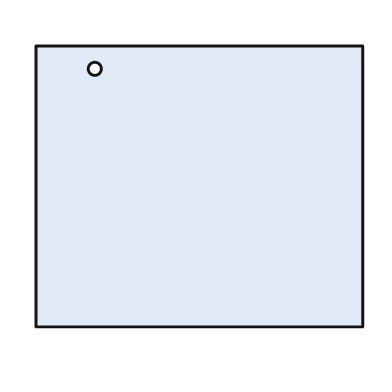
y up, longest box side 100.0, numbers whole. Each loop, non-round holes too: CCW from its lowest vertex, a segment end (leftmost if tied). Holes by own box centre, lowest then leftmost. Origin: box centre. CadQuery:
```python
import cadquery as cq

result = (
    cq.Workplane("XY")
    .moveTo(-50.0, -43.0)
    .lineTo(50.0, -43.0)
    .lineTo(50.0, 43.0)
    .lineTo(-50.0, 43.0)
    .close()
    .moveTo(-32.0, 36.0)
    .circle(2.0)
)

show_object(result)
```